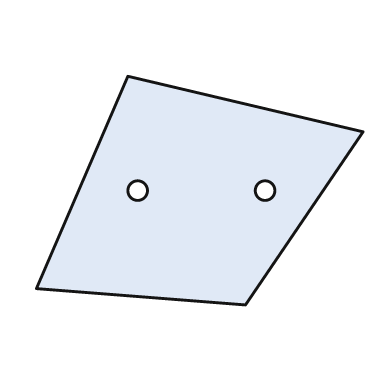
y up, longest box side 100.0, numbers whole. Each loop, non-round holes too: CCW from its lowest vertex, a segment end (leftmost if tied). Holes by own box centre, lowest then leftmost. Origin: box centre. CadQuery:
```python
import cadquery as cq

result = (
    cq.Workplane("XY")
    .moveTo(14.0, -35.0)
    .lineTo(50.0, 18.0)
    .lineTo(-22.0, 35.0)
    .lineTo(-50.0, -30.0)
    .close()
    .moveTo(-19.0, 0.0)
    .circle(3.0)
    .moveTo(20.0, 0.0)
    .circle(3.0)
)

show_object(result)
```